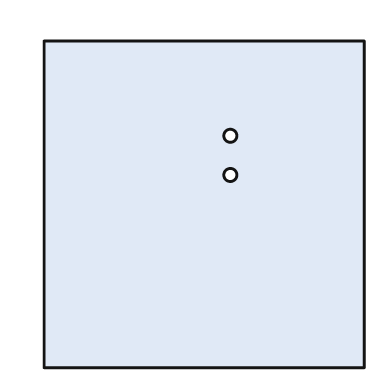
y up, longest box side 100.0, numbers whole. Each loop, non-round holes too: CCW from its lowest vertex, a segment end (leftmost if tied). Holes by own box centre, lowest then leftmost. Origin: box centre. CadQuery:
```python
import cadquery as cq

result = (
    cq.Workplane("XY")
    .moveTo(-49.0, -50.0)
    .lineTo(49.0, -50.0)
    .lineTo(49.0, 50.0)
    .lineTo(-49.0, 50.0)
    .close()
    .moveTo(8.0, 9.0)
    .circle(2.0)
    .moveTo(8.0, 21.0)
    .circle(2.0)
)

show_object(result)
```